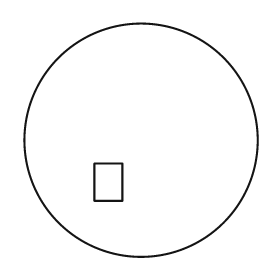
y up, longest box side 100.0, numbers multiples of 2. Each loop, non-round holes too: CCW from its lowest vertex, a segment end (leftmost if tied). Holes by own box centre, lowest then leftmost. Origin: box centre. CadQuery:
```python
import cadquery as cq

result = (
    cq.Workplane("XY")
    .moveTo(0.0, 0.0)
    .circle(50.0)
    .moveTo(-20.0, -26.0)
    .lineTo(-8.0, -26.0)
    .lineTo(-8.0, -10.0)
    .lineTo(-20.0, -10.0)
    .close()
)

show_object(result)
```